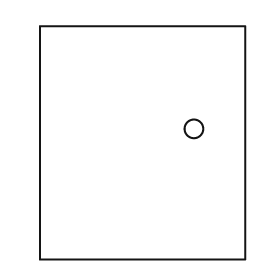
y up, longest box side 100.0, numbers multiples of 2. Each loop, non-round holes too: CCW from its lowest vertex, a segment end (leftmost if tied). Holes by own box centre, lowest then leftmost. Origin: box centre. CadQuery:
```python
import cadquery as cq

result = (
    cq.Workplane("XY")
    .moveTo(-44.0, -50.0)
    .lineTo(44.0, -50.0)
    .lineTo(44.0, 50.0)
    .lineTo(-44.0, 50.0)
    .close()
    .moveTo(22.0, 6.0)
    .circle(4.0)
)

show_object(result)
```